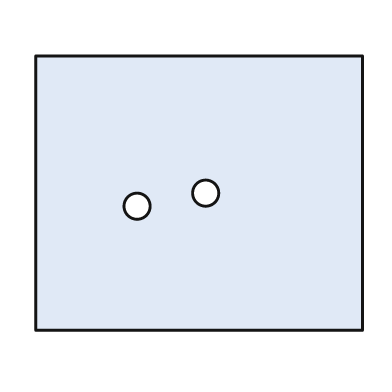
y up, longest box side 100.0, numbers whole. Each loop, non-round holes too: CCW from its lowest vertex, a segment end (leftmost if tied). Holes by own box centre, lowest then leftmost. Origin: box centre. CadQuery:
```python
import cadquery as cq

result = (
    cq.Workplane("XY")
    .moveTo(-50.0, -42.0)
    .lineTo(50.0, -42.0)
    .lineTo(50.0, 42.0)
    .lineTo(-50.0, 42.0)
    .close()
    .moveTo(-19.0, -4.0)
    .circle(4.0)
    .moveTo(2.0, 0.0)
    .circle(4.0)
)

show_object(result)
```